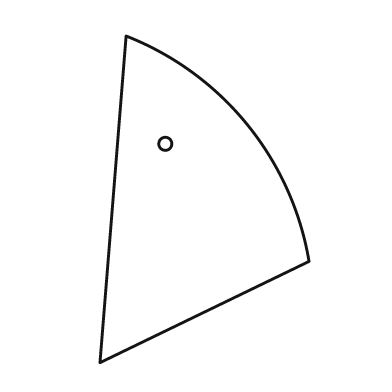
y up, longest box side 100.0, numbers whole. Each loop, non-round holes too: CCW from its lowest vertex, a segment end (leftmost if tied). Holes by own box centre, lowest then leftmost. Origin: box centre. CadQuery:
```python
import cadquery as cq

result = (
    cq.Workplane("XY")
    .moveTo(-32.0, -50.0)
    .lineTo(32.0, -19.0)
    .threePointArc((13.0, 23.0), (-24.0, 50.0))
    .close()
    .moveTo(-12.0, 17.0)
    .circle(2.0)
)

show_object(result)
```